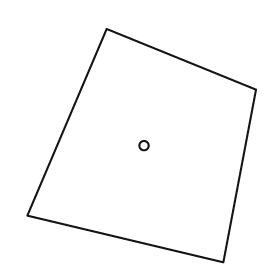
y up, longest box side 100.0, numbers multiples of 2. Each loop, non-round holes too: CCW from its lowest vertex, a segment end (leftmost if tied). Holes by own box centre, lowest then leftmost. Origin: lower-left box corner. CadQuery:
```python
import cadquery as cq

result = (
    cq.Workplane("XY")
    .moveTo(84.0, 0.0)
    .lineTo(98.0, 74.0)
    .lineTo(34.0, 100.0)
    .lineTo(0.0, 20.0)
    .close()
    .moveTo(50.0, 50.0)
    .circle(2.0)
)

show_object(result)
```